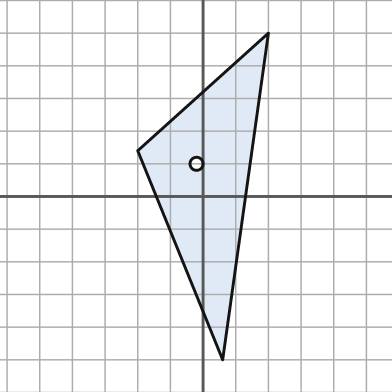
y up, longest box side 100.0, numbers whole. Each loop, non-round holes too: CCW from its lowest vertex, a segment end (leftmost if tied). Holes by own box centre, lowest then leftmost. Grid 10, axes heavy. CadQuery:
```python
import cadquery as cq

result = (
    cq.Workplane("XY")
    .moveTo(6.0, -50.0)
    .lineTo(20.0, 50.0)
    .lineTo(-20.0, 14.0)
    .close()
    .moveTo(-2.0, 10.0)
    .circle(2.0)
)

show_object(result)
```